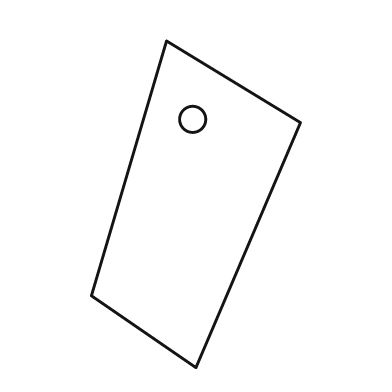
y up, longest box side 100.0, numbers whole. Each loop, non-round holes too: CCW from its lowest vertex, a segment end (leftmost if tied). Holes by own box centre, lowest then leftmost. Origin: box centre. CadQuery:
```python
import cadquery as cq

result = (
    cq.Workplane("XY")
    .moveTo(0.0, -50.0)
    .lineTo(32.0, 25.0)
    .lineTo(-9.0, 50.0)
    .lineTo(-32.0, -28.0)
    .close()
    .moveTo(-1.0, 26.0)
    .circle(4.0)
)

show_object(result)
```